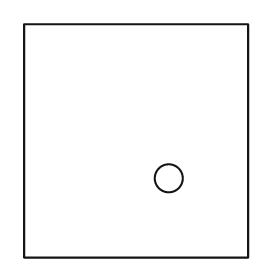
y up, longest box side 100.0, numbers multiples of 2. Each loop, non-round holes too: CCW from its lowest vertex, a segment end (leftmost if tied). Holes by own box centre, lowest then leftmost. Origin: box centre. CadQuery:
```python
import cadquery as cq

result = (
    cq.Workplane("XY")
    .moveTo(-48.0, -50.0)
    .lineTo(48.0, -50.0)
    .lineTo(48.0, 50.0)
    .lineTo(-48.0, 50.0)
    .close()
    .moveTo(14.0, -16.0)
    .circle(6.0)
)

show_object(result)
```